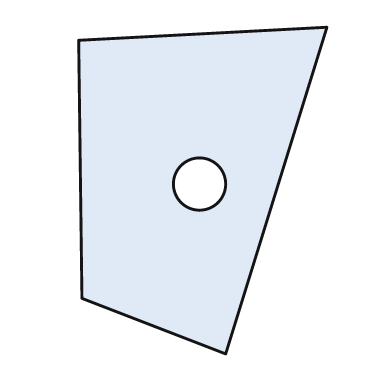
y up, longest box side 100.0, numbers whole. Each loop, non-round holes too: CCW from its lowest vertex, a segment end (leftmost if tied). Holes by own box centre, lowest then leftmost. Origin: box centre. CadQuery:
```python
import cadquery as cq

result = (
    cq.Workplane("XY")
    .moveTo(7.0, -50.0)
    .lineTo(38.0, 50.0)
    .lineTo(-38.0, 46.0)
    .lineTo(-37.0, -33.0)
    .close()
    .moveTo(-1.0, 2.0)
    .circle(8.0)
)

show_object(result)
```